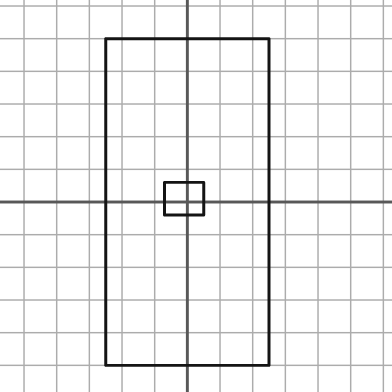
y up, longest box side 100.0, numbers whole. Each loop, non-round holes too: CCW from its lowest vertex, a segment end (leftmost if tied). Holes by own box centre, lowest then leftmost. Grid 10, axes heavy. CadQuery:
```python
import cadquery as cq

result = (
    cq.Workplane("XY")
    .moveTo(-25.0, -50.0)
    .lineTo(25.0, -50.0)
    .lineTo(25.0, 50.0)
    .lineTo(-25.0, 50.0)
    .close()
    .moveTo(-7.0, -4.0)
    .lineTo(5.0, -4.0)
    .lineTo(5.0, 6.0)
    .lineTo(-7.0, 6.0)
    .close()
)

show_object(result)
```